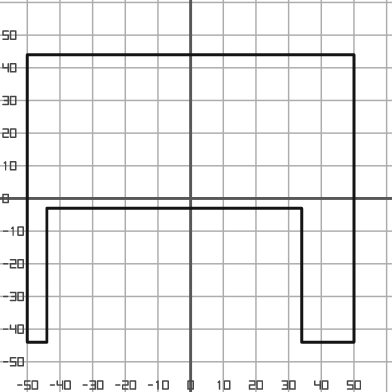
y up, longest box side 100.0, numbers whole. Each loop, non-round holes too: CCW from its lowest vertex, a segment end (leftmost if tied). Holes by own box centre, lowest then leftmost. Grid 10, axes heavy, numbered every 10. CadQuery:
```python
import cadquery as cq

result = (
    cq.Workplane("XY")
    .moveTo(-50.0, -44.0)
    .lineTo(-44.0, -44.0)
    .lineTo(-44.0, -3.0)
    .lineTo(34.0, -3.0)
    .lineTo(34.0, -44.0)
    .lineTo(50.0, -44.0)
    .lineTo(50.0, 44.0)
    .lineTo(-50.0, 44.0)
    .close()
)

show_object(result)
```